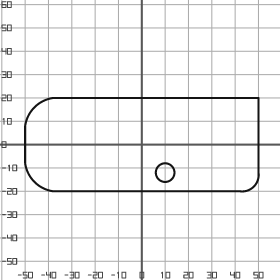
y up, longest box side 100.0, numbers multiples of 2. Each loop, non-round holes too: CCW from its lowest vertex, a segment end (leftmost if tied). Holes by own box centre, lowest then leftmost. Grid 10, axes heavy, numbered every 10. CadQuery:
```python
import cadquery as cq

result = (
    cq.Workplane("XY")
    .moveTo(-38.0, -20.0)
    .lineTo(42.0, -20.0)
    .threePointArc((48.0, -18.0), (50.0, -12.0))
    .lineTo(50.0, 20.0)
    .lineTo(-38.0, 20.0)
    .threePointArc((-46.0, 16.0), (-50.0, 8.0))
    .lineTo(-50.0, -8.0)
    .threePointArc((-46.0, -16.0), (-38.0, -20.0))
    .close()
    .moveTo(10.0, -12.0)
    .circle(4.0)
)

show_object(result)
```